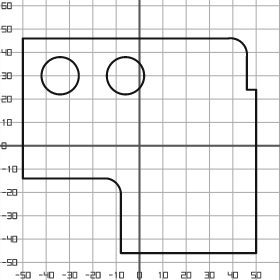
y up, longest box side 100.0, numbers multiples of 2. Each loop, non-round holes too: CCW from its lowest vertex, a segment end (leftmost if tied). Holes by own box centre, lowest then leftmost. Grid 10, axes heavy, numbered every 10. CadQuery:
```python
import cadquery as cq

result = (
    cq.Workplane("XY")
    .moveTo(-8.0, -46.0)
    .lineTo(50.0, -46.0)
    .lineTo(50.0, 24.0)
    .lineTo(46.0, 24.0)
    .lineTo(46.0, 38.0)
    .threePointArc((44.0, 44.0), (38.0, 46.0))
    .lineTo(-50.0, 46.0)
    .lineTo(-50.0, -14.0)
    .lineTo(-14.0, -14.0)
    .threePointArc((-10.0, -16.0), (-8.0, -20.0))
    .close()
    .moveTo(-34.0, 30.0)
    .circle(8.0)
    .moveTo(-6.0, 30.0)
    .circle(8.0)
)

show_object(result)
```